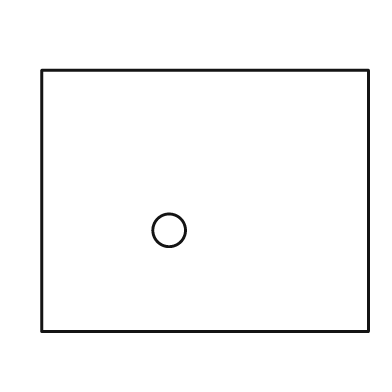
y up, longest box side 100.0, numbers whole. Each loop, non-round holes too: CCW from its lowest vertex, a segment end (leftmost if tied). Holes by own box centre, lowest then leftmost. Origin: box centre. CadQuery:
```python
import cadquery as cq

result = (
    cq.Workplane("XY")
    .moveTo(-50.0, -40.0)
    .lineTo(50.0, -40.0)
    .lineTo(50.0, 40.0)
    .lineTo(-50.0, 40.0)
    .close()
    .moveTo(-11.0, -9.0)
    .circle(5.0)
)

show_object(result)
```